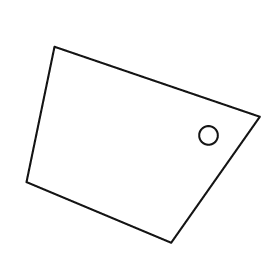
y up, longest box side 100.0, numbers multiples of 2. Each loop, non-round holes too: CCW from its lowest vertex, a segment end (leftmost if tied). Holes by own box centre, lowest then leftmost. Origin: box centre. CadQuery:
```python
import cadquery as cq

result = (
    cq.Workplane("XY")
    .moveTo(12.0, -42.0)
    .lineTo(50.0, 12.0)
    .lineTo(-38.0, 42.0)
    .lineTo(-50.0, -16.0)
    .close()
    .moveTo(28.0, 4.0)
    .circle(4.0)
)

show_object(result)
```